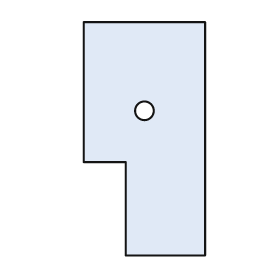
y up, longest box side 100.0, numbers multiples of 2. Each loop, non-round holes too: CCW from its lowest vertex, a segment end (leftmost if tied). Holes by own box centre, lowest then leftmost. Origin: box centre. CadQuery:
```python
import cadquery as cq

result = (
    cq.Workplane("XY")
    .moveTo(-8.0, -50.0)
    .lineTo(26.0, -50.0)
    .lineTo(26.0, 50.0)
    .lineTo(-26.0, 50.0)
    .lineTo(-26.0, -10.0)
    .lineTo(-8.0, -10.0)
    .close()
    .moveTo(0.0, 12.0)
    .circle(4.0)
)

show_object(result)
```